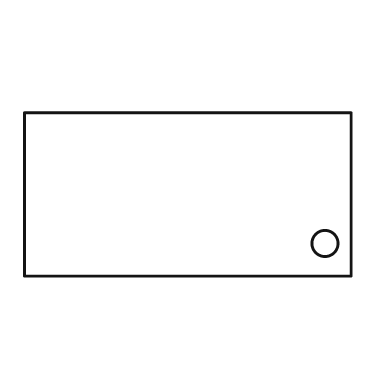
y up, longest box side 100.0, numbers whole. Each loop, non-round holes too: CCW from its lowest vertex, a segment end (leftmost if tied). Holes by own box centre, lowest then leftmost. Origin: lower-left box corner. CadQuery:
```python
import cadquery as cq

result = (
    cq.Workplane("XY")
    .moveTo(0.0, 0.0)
    .lineTo(100.0, 0.0)
    .lineTo(100.0, 50.0)
    .lineTo(0.0, 50.0)
    .close()
    .moveTo(92.0, 10.0)
    .circle(4.0)
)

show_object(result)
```